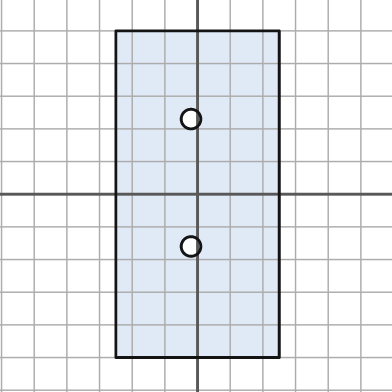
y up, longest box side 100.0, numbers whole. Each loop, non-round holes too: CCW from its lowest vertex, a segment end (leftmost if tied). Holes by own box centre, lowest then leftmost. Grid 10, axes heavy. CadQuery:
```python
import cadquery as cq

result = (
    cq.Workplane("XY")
    .moveTo(-25.0, -50.0)
    .lineTo(25.0, -50.0)
    .lineTo(25.0, 50.0)
    .lineTo(-25.0, 50.0)
    .close()
    .moveTo(-2.0, -16.0)
    .circle(3.0)
    .moveTo(-2.0, 23.0)
    .circle(3.0)
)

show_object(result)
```